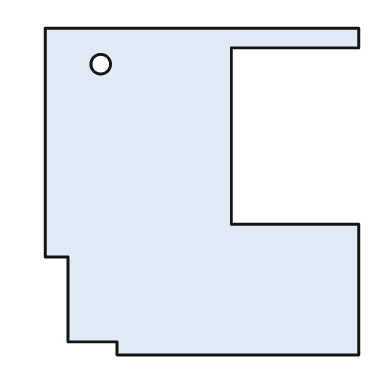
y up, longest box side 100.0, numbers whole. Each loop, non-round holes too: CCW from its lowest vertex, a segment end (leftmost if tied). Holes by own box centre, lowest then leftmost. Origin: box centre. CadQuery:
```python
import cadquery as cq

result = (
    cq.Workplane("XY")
    .moveTo(-26.0, -50.0)
    .lineTo(48.0, -50.0)
    .lineTo(48.0, -10.0)
    .lineTo(9.0, -10.0)
    .lineTo(9.0, 44.0)
    .lineTo(48.0, 44.0)
    .lineTo(48.0, 50.0)
    .lineTo(-48.0, 50.0)
    .lineTo(-48.0, -20.0)
    .lineTo(-41.0, -20.0)
    .lineTo(-41.0, -46.0)
    .lineTo(-26.0, -46.0)
    .close()
    .moveTo(-31.0, 39.0)
    .circle(3.0)
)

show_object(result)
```